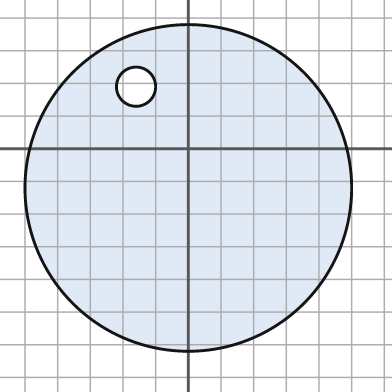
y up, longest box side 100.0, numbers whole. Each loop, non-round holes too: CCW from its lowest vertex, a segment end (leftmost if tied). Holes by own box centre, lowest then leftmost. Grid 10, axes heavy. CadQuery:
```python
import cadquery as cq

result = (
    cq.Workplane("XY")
    .moveTo(0.0, -12.0)
    .circle(50.0)
    .moveTo(-16.0, 19.0)
    .circle(6.0)
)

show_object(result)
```